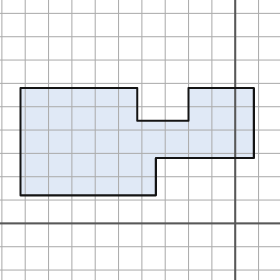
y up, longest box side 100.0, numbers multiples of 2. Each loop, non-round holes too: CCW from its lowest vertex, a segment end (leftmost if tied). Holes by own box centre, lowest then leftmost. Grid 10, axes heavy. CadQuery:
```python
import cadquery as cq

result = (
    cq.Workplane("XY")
    .moveTo(-92.0, 12.0)
    .lineTo(-34.0, 12.0)
    .lineTo(-34.0, 28.0)
    .lineTo(8.0, 28.0)
    .lineTo(8.0, 58.0)
    .lineTo(-20.0, 58.0)
    .lineTo(-20.0, 44.0)
    .lineTo(-42.0, 44.0)
    .lineTo(-42.0, 58.0)
    .lineTo(-92.0, 58.0)
    .close()
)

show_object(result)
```